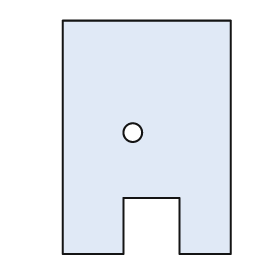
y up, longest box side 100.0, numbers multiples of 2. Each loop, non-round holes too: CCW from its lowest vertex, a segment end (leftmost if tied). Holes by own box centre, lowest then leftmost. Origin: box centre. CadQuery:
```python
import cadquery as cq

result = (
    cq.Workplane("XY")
    .moveTo(-36.0, -50.0)
    .lineTo(-10.0, -50.0)
    .lineTo(-10.0, -26.0)
    .lineTo(14.0, -26.0)
    .lineTo(14.0, -50.0)
    .lineTo(36.0, -50.0)
    .lineTo(36.0, 50.0)
    .lineTo(-36.0, 50.0)
    .close()
    .moveTo(-6.0, 2.0)
    .circle(4.0)
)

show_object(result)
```